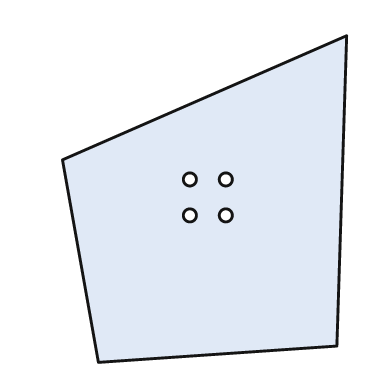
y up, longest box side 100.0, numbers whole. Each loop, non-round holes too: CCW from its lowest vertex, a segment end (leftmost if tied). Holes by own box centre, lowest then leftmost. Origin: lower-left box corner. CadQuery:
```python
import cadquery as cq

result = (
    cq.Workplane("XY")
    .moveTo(11.0, 0.0)
    .lineTo(84.0, 5.0)
    .lineTo(87.0, 100.0)
    .lineTo(0.0, 62.0)
    .close()
    .moveTo(39.0, 45.0)
    .circle(2.0)
    .moveTo(50.0, 45.0)
    .circle(2.0)
    .moveTo(39.0, 56.0)
    .circle(2.0)
    .moveTo(50.0, 56.0)
    .circle(2.0)
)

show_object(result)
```